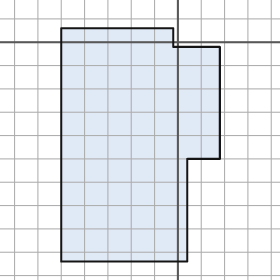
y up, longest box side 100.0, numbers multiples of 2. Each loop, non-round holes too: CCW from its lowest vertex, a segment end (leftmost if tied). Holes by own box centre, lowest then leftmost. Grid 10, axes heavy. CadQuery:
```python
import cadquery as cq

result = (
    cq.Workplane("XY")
    .moveTo(-50.0, -94.0)
    .lineTo(4.0, -94.0)
    .lineTo(4.0, -50.0)
    .lineTo(18.0, -50.0)
    .lineTo(18.0, -2.0)
    .lineTo(-2.0, -2.0)
    .lineTo(-2.0, 6.0)
    .lineTo(-50.0, 6.0)
    .close()
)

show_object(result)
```